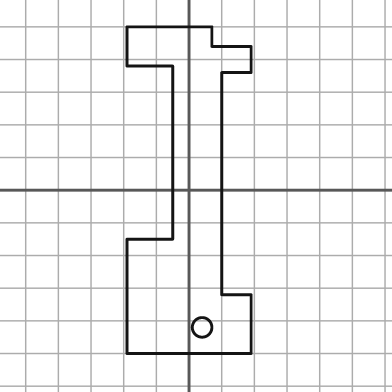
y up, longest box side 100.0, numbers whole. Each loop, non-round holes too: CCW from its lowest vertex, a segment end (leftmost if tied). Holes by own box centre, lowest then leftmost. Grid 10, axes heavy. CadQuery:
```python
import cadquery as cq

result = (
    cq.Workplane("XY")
    .moveTo(-19.0, -50.0)
    .lineTo(19.0, -50.0)
    .lineTo(19.0, -32.0)
    .lineTo(10.0, -32.0)
    .lineTo(10.0, 36.0)
    .lineTo(19.0, 36.0)
    .lineTo(19.0, 44.0)
    .lineTo(7.0, 44.0)
    .lineTo(7.0, 50.0)
    .lineTo(-19.0, 50.0)
    .lineTo(-19.0, 38.0)
    .lineTo(-5.0, 38.0)
    .lineTo(-5.0, -15.0)
    .lineTo(-19.0, -15.0)
    .close()
    .moveTo(4.0, -42.0)
    .circle(3.0)
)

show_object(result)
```